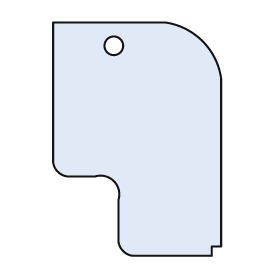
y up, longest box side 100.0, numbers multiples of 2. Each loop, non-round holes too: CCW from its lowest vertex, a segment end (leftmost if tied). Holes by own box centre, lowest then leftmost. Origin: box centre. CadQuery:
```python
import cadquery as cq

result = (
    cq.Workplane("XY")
    .moveTo(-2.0, -50.0)
    .lineTo(32.0, -50.0)
    .lineTo(32.0, -46.0)
    .lineTo(36.0, -46.0)
    .lineTo(36.0, 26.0)
    .threePointArc((28.0, 42.0), (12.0, 50.0))
    .lineTo(-36.0, 50.0)
    .lineTo(-36.0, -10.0)
    .threePointArc((-34.0, -14.0), (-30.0, -16.0))
    .lineTo(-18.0, -16.0)
    .threePointArc((-10.0, -18.0), (-8.0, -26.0))
    .lineTo(-8.0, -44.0)
    .threePointArc((-6.0, -48.0), (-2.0, -50.0))
    .close()
    .moveTo(-10.0, 40.0)
    .circle(4.0)
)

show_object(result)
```